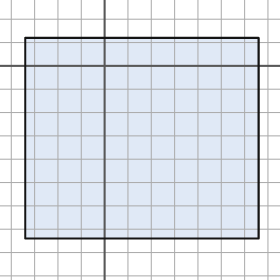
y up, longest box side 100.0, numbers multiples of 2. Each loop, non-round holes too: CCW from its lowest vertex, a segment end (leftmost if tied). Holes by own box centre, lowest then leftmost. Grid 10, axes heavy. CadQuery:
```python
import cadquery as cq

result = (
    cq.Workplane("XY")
    .moveTo(-34.0, -74.0)
    .lineTo(66.0, -74.0)
    .lineTo(66.0, 12.0)
    .lineTo(-34.0, 12.0)
    .close()
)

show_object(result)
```